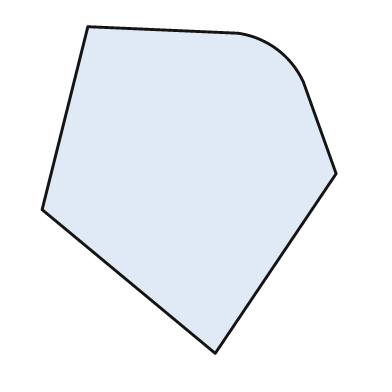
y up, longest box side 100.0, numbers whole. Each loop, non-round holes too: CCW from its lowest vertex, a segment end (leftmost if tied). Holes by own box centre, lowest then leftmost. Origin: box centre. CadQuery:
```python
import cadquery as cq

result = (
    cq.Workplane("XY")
    .moveTo(8.0, -50.0)
    .lineTo(45.0, 5.0)
    .lineTo(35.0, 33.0)
    .threePointArc((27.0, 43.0), (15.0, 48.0))
    .lineTo(-31.0, 50.0)
    .lineTo(-45.0, -6.0)
    .close()
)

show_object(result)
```